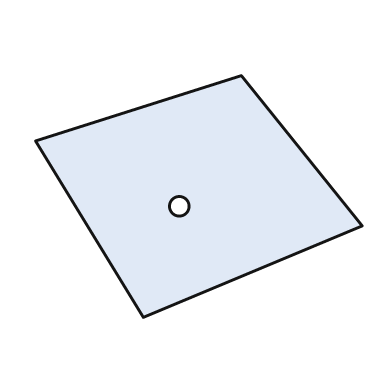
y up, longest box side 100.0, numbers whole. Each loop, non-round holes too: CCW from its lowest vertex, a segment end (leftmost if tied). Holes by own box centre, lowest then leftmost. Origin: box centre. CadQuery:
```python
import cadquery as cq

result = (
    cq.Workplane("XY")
    .moveTo(-17.0, -37.0)
    .lineTo(50.0, -9.0)
    .lineTo(13.0, 37.0)
    .lineTo(-50.0, 17.0)
    .close()
    .moveTo(-6.0, -3.0)
    .circle(3.0)
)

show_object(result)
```